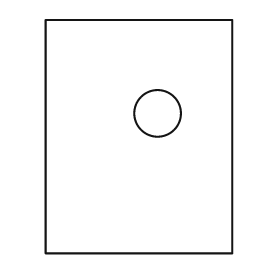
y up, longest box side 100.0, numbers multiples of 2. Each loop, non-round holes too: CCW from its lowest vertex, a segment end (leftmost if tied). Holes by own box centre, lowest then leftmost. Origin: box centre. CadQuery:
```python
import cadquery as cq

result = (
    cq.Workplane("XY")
    .moveTo(-40.0, -50.0)
    .lineTo(40.0, -50.0)
    .lineTo(40.0, 50.0)
    .lineTo(-40.0, 50.0)
    .close()
    .moveTo(8.0, 10.0)
    .circle(10.0)
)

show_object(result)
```